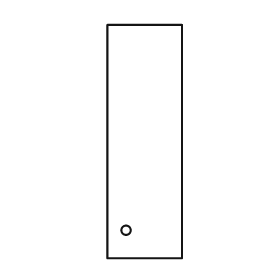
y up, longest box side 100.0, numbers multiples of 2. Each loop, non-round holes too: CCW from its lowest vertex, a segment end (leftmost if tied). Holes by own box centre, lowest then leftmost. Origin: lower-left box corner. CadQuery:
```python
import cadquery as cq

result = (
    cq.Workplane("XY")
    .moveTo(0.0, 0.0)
    .lineTo(32.0, 0.0)
    .lineTo(32.0, 100.0)
    .lineTo(0.0, 100.0)
    .close()
    .moveTo(8.0, 12.0)
    .circle(2.0)
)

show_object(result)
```